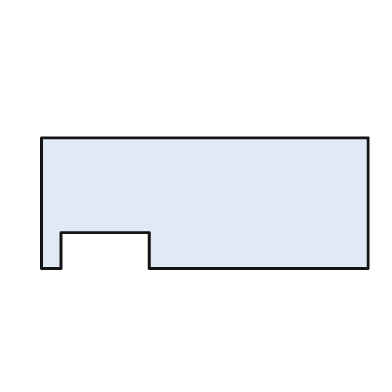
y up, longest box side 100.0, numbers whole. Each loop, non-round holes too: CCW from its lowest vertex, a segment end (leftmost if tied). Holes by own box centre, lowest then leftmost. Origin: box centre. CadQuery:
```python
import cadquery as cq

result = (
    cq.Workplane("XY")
    .moveTo(-50.0, -20.0)
    .lineTo(-44.0, -20.0)
    .lineTo(-44.0, -9.0)
    .lineTo(-17.0, -9.0)
    .lineTo(-17.0, -20.0)
    .lineTo(50.0, -20.0)
    .lineTo(50.0, 20.0)
    .lineTo(-50.0, 20.0)
    .close()
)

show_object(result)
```